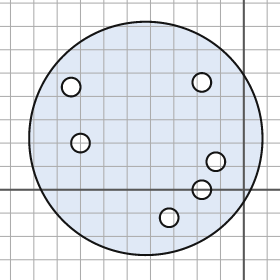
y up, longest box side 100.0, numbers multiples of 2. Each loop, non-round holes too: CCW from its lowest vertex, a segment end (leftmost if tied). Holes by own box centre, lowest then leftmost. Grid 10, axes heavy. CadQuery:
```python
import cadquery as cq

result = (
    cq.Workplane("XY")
    .moveTo(-42.0, 22.0)
    .circle(50.0)
    .moveTo(-32.0, -12.0)
    .circle(4.0)
    .moveTo(-18.0, 0.0)
    .circle(4.0)
    .moveTo(-12.0, 12.0)
    .circle(4.0)
    .moveTo(-70.0, 20.0)
    .circle(4.0)
    .moveTo(-74.0, 44.0)
    .circle(4.0)
    .moveTo(-18.0, 46.0)
    .circle(4.0)
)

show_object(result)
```